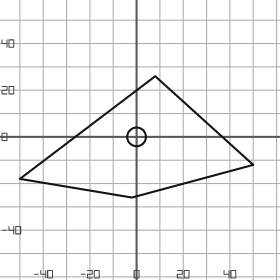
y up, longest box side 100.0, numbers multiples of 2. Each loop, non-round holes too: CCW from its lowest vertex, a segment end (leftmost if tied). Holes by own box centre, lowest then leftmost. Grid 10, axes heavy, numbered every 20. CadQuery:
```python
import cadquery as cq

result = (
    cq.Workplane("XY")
    .moveTo(-2.0, -26.0)
    .lineTo(50.0, -12.0)
    .lineTo(8.0, 26.0)
    .lineTo(-50.0, -18.0)
    .close()
    .moveTo(0.0, 0.0)
    .circle(4.0)
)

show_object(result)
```